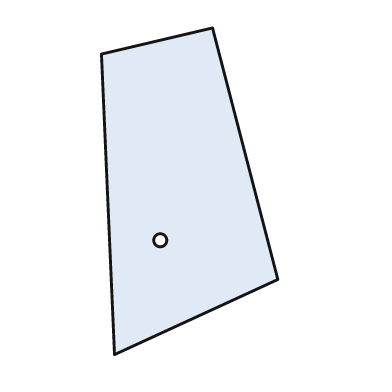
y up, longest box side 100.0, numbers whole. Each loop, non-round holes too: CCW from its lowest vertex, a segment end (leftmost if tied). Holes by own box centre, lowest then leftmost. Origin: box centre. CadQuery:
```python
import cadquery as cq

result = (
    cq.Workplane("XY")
    .moveTo(-23.0, -50.0)
    .lineTo(27.0, -27.0)
    .lineTo(7.0, 50.0)
    .lineTo(-27.0, 42.0)
    .close()
    .moveTo(-9.0, -15.0)
    .circle(2.0)
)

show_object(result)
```